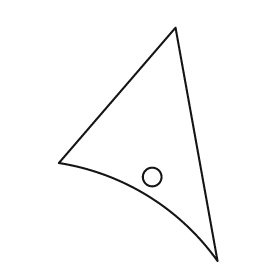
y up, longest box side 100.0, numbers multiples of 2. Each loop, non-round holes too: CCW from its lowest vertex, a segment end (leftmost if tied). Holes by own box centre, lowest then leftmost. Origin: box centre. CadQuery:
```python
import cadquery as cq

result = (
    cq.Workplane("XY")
    .moveTo(34.0, -50.0)
    .lineTo(16.0, 50.0)
    .lineTo(-34.0, -8.0)
    .threePointArc((4.0, -22.0), (34.0, -50.0))
    .close()
    .moveTo(6.0, -14.0)
    .circle(4.0)
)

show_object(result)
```